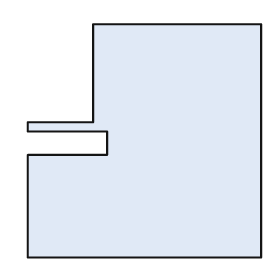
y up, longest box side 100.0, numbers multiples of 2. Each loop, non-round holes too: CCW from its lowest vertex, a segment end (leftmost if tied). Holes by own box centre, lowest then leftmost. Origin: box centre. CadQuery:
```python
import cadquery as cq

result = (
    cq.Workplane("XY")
    .moveTo(-50.0, -50.0)
    .lineTo(50.0, -50.0)
    .lineTo(50.0, 50.0)
    .lineTo(-22.0, 50.0)
    .lineTo(-22.0, 8.0)
    .lineTo(-50.0, 8.0)
    .lineTo(-50.0, 4.0)
    .lineTo(-16.0, 4.0)
    .lineTo(-16.0, -6.0)
    .lineTo(-50.0, -6.0)
    .close()
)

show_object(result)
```